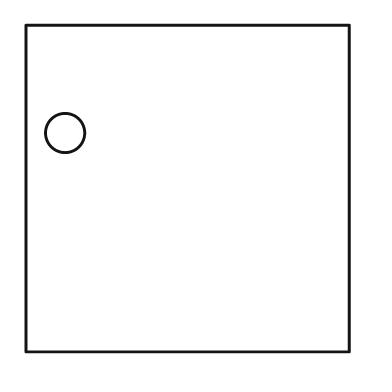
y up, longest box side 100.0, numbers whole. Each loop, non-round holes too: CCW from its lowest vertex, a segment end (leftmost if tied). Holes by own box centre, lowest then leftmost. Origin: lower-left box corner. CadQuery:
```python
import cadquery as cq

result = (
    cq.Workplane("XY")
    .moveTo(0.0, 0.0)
    .lineTo(99.0, 0.0)
    .lineTo(99.0, 100.0)
    .lineTo(0.0, 100.0)
    .close()
    .moveTo(12.0, 67.0)
    .circle(6.0)
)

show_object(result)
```